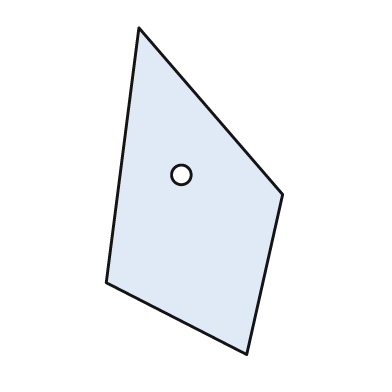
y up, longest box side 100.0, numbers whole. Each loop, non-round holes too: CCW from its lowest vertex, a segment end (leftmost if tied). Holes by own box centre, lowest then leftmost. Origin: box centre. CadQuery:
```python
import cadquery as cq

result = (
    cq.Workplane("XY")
    .moveTo(16.0, -50.0)
    .lineTo(27.0, -1.0)
    .lineTo(-17.0, 50.0)
    .lineTo(-27.0, -28.0)
    .close()
    .moveTo(-4.0, 5.0)
    .circle(3.0)
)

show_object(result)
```